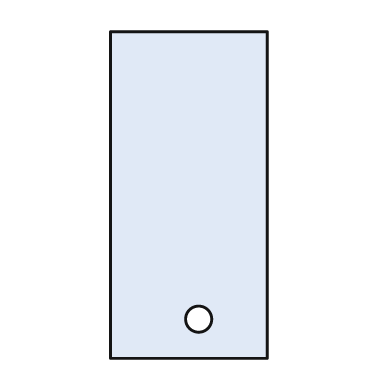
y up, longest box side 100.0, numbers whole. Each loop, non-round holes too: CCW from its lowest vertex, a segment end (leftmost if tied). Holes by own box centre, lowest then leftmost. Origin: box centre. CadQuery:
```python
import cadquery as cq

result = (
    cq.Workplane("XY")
    .moveTo(-24.0, -50.0)
    .lineTo(24.0, -50.0)
    .lineTo(24.0, 50.0)
    .lineTo(-24.0, 50.0)
    .close()
    .moveTo(3.0, -38.0)
    .circle(4.0)
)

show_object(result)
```